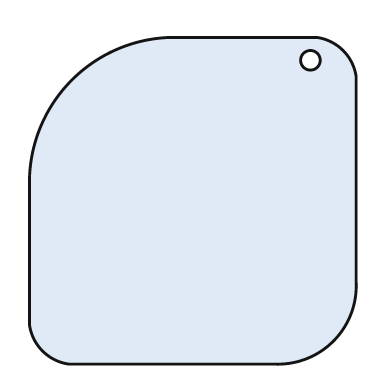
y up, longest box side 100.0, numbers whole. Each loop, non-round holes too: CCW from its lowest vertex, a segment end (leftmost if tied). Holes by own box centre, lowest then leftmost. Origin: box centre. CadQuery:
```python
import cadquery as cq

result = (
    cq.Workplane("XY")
    .moveTo(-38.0, -50.0)
    .lineTo(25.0, -50.0)
    .threePointArc((43.0, -43.0), (50.0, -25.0))
    .lineTo(50.0, 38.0)
    .threePointArc((46.0, 46.0), (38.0, 50.0))
    .lineTo(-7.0, 50.0)
    .threePointArc((-37.0, 37.0), (-50.0, 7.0))
    .lineTo(-50.0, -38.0)
    .threePointArc((-46.0, -46.0), (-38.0, -50.0))
    .close()
    .moveTo(36.0, 43.0)
    .circle(3.0)
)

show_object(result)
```